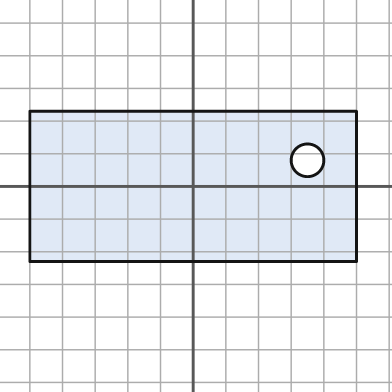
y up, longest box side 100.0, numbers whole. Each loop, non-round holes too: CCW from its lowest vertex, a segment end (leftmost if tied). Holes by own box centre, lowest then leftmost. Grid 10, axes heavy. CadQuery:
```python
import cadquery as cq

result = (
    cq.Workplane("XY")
    .moveTo(-50.0, -23.0)
    .lineTo(50.0, -23.0)
    .lineTo(50.0, 23.0)
    .lineTo(-50.0, 23.0)
    .close()
    .moveTo(35.0, 8.0)
    .circle(5.0)
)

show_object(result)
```